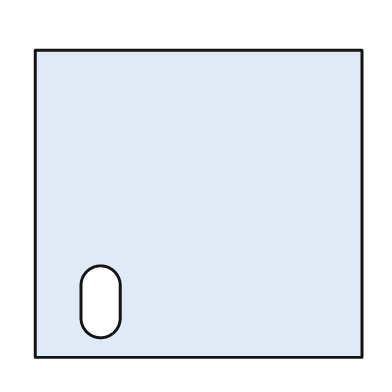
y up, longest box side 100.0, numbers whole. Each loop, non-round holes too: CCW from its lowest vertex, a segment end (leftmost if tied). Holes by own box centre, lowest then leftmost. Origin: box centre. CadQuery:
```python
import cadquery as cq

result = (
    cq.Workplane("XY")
    .moveTo(-50.0, -47.0)
    .lineTo(50.0, -47.0)
    .lineTo(50.0, 47.0)
    .lineTo(-50.0, 47.0)
    .close()
    .moveTo(-36.0, -35.0)
    .threePointArc((-30.0, -41.0), (-24.0, -35.0))
    .lineTo(-24.0, -25.0)
    .threePointArc((-30.0, -19.0), (-36.0, -25.0))
    .close()
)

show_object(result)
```